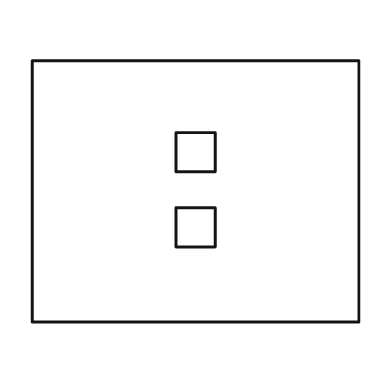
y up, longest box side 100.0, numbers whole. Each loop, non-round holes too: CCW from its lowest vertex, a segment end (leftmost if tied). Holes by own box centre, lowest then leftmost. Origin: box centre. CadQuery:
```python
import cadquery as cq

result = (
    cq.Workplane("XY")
    .moveTo(-50.0, -40.0)
    .lineTo(50.0, -40.0)
    .lineTo(50.0, 40.0)
    .lineTo(-50.0, 40.0)
    .close()
    .moveTo(-6.0, -17.0)
    .lineTo(6.0, -17.0)
    .lineTo(6.0, -5.0)
    .lineTo(-6.0, -5.0)
    .close()
    .moveTo(-6.0, 6.0)
    .lineTo(6.0, 6.0)
    .lineTo(6.0, 18.0)
    .lineTo(-6.0, 18.0)
    .close()
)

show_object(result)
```